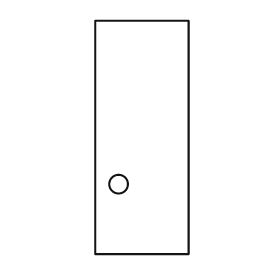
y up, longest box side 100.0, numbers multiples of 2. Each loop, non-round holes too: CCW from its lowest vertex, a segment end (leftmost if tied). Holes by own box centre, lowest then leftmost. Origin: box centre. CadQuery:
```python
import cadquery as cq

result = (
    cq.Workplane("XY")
    .moveTo(-20.0, -50.0)
    .lineTo(20.0, -50.0)
    .lineTo(20.0, 50.0)
    .lineTo(-20.0, 50.0)
    .close()
    .moveTo(-10.0, -20.0)
    .circle(4.0)
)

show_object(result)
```